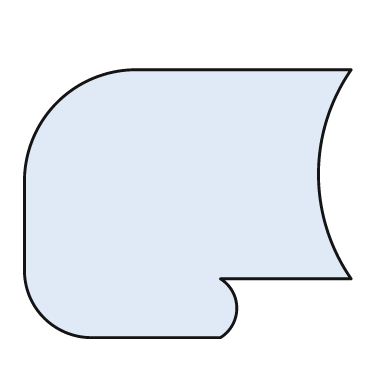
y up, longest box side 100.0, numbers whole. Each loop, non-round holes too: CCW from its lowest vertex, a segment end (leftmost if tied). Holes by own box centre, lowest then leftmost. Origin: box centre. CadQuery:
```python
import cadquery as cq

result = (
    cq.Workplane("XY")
    .moveTo(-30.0, -41.0)
    .lineTo(10.0, -41.0)
    .threePointArc((15.0, -32.0), (10.0, -23.0))
    .lineTo(50.0, -23.0)
    .threePointArc((40.0, 9.0), (50.0, 41.0))
    .lineTo(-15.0, 41.0)
    .threePointArc((-40.0, 31.0), (-50.0, 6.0))
    .lineTo(-50.0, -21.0)
    .threePointArc((-44.0, -35.0), (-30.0, -41.0))
    .close()
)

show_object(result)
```